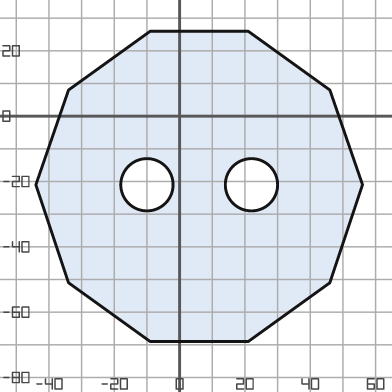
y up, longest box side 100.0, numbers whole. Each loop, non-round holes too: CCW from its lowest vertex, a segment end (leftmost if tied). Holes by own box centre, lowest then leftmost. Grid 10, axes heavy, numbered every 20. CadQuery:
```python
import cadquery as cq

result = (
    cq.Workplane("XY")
    .moveTo(-9.0, -69.0)
    .lineTo(21.0, -69.0)
    .lineTo(46.0, -51.0)
    .lineTo(56.0, -21.0)
    .lineTo(46.0, 8.0)
    .lineTo(21.0, 26.0)
    .lineTo(-9.0, 26.0)
    .lineTo(-34.0, 8.0)
    .lineTo(-44.0, -21.0)
    .lineTo(-34.0, -51.0)
    .close()
    .moveTo(-10.0, -21.0)
    .circle(8.0)
    .moveTo(22.0, -21.0)
    .circle(8.0)
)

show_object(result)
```